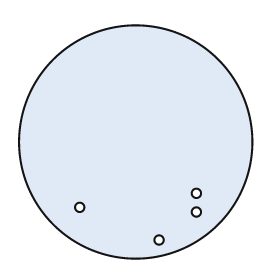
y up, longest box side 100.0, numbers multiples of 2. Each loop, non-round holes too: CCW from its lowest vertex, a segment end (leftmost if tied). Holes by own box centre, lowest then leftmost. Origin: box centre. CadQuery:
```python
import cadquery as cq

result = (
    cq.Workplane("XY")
    .moveTo(0.0, 0.0)
    .circle(50.0)
    .moveTo(10.0, -42.0)
    .circle(2.0)
    .moveTo(26.0, -30.0)
    .circle(2.0)
    .moveTo(-24.0, -28.0)
    .circle(2.0)
    .moveTo(26.0, -22.0)
    .circle(2.0)
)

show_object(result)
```